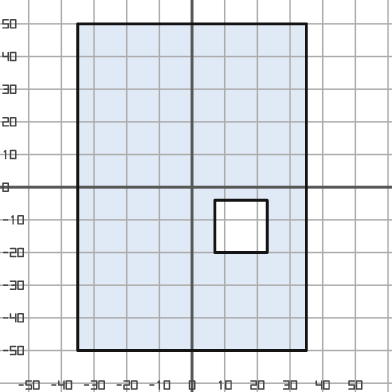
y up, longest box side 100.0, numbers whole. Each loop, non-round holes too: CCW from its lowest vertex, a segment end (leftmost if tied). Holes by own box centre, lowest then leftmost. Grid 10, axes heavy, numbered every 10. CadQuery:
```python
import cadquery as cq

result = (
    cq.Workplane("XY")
    .moveTo(-35.0, -50.0)
    .lineTo(35.0, -50.0)
    .lineTo(35.0, 50.0)
    .lineTo(-35.0, 50.0)
    .close()
    .moveTo(7.0, -20.0)
    .lineTo(23.0, -20.0)
    .lineTo(23.0, -4.0)
    .lineTo(7.0, -4.0)
    .close()
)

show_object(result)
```